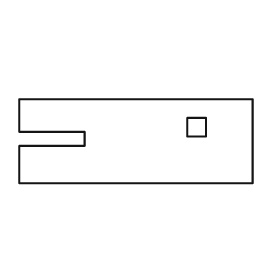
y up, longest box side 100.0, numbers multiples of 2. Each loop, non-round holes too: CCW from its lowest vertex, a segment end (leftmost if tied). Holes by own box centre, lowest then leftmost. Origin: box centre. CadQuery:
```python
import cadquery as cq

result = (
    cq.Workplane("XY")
    .moveTo(-50.0, -18.0)
    .lineTo(50.0, -18.0)
    .lineTo(50.0, 18.0)
    .lineTo(-50.0, 18.0)
    .lineTo(-50.0, 4.0)
    .lineTo(-22.0, 4.0)
    .lineTo(-22.0, -2.0)
    .lineTo(-50.0, -2.0)
    .close()
    .moveTo(22.0, 2.0)
    .lineTo(30.0, 2.0)
    .lineTo(30.0, 10.0)
    .lineTo(22.0, 10.0)
    .close()
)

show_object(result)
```